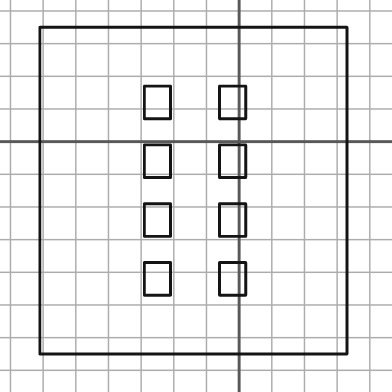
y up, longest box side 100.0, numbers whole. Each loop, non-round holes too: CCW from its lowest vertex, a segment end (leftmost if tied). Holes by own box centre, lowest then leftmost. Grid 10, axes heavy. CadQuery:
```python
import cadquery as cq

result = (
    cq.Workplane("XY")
    .moveTo(-61.0, -65.0)
    .lineTo(33.0, -65.0)
    .lineTo(33.0, 35.0)
    .lineTo(-61.0, 35.0)
    .close()
    .moveTo(-29.0, -47.0)
    .lineTo(-21.0, -47.0)
    .lineTo(-21.0, -37.0)
    .lineTo(-29.0, -37.0)
    .close()
    .moveTo(-6.0, -47.0)
    .lineTo(2.0, -47.0)
    .lineTo(2.0, -37.0)
    .lineTo(-6.0, -37.0)
    .close()
    .moveTo(-29.0, -29.0)
    .lineTo(-21.0, -29.0)
    .lineTo(-21.0, -19.0)
    .lineTo(-29.0, -19.0)
    .close()
    .moveTo(-6.0, -29.0)
    .lineTo(2.0, -29.0)
    .lineTo(2.0, -19.0)
    .lineTo(-6.0, -19.0)
    .close()
    .moveTo(-29.0, -11.0)
    .lineTo(-21.0, -11.0)
    .lineTo(-21.0, -1.0)
    .lineTo(-29.0, -1.0)
    .close()
    .moveTo(-6.0, -11.0)
    .lineTo(2.0, -11.0)
    .lineTo(2.0, -1.0)
    .lineTo(-6.0, -1.0)
    .close()
    .moveTo(-29.0, 7.0)
    .lineTo(-21.0, 7.0)
    .lineTo(-21.0, 17.0)
    .lineTo(-29.0, 17.0)
    .close()
    .moveTo(-6.0, 7.0)
    .lineTo(2.0, 7.0)
    .lineTo(2.0, 17.0)
    .lineTo(-6.0, 17.0)
    .close()
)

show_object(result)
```